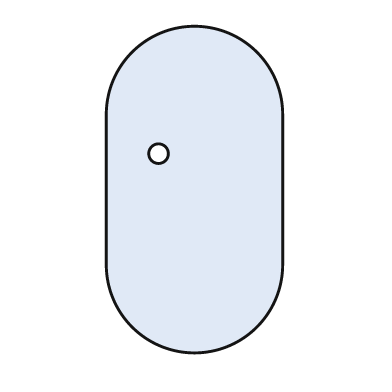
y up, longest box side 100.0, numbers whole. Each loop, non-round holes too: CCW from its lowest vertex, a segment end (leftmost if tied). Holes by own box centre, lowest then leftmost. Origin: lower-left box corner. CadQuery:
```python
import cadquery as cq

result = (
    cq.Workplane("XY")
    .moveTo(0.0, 27.0)
    .threePointArc((27.0, 0.0), (54.0, 27.0))
    .lineTo(54.0, 73.0)
    .threePointArc((27.0, 100.0), (0.0, 73.0))
    .close()
    .moveTo(16.0, 61.0)
    .circle(3.0)
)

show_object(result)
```